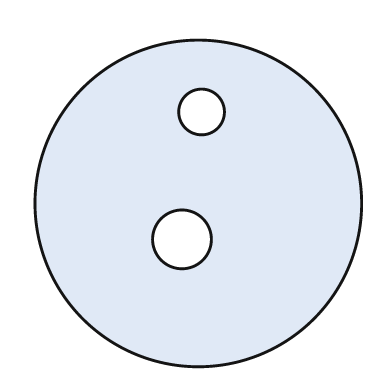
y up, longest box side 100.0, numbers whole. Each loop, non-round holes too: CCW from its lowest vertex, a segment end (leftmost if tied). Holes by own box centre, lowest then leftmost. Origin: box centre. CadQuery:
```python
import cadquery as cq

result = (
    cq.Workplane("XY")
    .moveTo(0.0, 0.0)
    .circle(50.0)
    .moveTo(-5.0, -11.0)
    .circle(9.0)
    .moveTo(1.0, 28.0)
    .circle(7.0)
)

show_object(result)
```